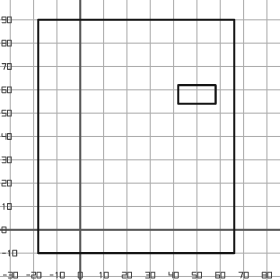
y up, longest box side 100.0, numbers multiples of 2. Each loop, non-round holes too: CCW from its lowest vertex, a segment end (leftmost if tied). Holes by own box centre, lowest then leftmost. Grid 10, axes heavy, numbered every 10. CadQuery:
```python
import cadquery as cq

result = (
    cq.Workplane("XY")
    .moveTo(-18.0, -10.0)
    .lineTo(66.0, -10.0)
    .lineTo(66.0, 90.0)
    .lineTo(-18.0, 90.0)
    .close()
    .moveTo(42.0, 54.0)
    .lineTo(58.0, 54.0)
    .lineTo(58.0, 62.0)
    .lineTo(42.0, 62.0)
    .close()
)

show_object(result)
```